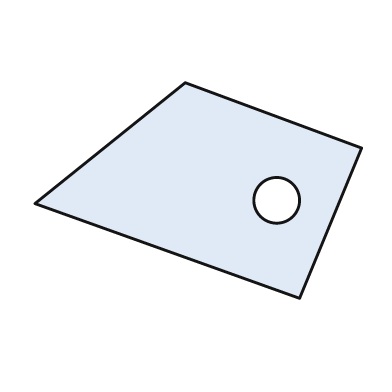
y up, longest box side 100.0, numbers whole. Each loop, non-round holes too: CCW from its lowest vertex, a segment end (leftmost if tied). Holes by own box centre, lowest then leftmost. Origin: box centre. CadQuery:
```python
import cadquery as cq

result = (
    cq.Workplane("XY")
    .moveTo(31.0, -33.0)
    .lineTo(50.0, 13.0)
    .lineTo(-4.0, 33.0)
    .lineTo(-50.0, -4.0)
    .close()
    .moveTo(24.0, -3.0)
    .circle(7.0)
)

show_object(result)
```